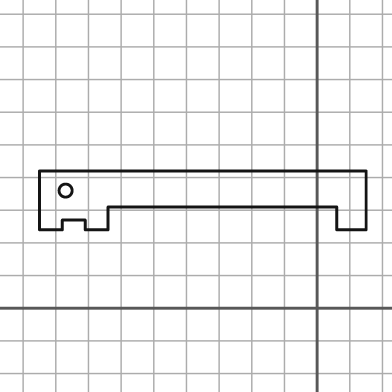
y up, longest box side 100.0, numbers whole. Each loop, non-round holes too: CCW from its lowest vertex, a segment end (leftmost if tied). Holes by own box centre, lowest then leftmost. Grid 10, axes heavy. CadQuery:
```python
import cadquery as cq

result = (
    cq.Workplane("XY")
    .moveTo(-85.0, 24.0)
    .lineTo(-78.0, 24.0)
    .lineTo(-78.0, 27.0)
    .lineTo(-71.0, 27.0)
    .lineTo(-71.0, 24.0)
    .lineTo(-64.0, 24.0)
    .lineTo(-64.0, 31.0)
    .lineTo(6.0, 31.0)
    .lineTo(6.0, 24.0)
    .lineTo(15.0, 24.0)
    .lineTo(15.0, 42.0)
    .lineTo(-85.0, 42.0)
    .close()
    .moveTo(-77.0, 36.0)
    .circle(2.0)
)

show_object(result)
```